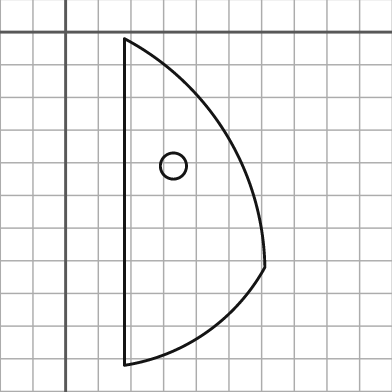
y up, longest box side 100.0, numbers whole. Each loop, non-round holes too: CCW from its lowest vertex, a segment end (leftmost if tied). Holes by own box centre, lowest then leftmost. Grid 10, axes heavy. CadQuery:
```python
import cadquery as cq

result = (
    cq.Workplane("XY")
    .moveTo(18.0, -102.0)
    .threePointArc((43.0, -92.0), (61.0, -72.0))
    .threePointArc((49.0, -31.0), (18.0, -2.0))
    .close()
    .moveTo(33.0, -41.0)
    .circle(4.0)
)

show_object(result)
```